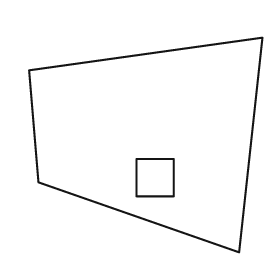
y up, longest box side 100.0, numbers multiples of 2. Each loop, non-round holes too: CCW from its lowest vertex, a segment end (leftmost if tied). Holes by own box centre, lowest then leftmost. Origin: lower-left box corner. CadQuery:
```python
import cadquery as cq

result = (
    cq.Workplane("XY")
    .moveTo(90.0, 0.0)
    .lineTo(100.0, 92.0)
    .lineTo(0.0, 78.0)
    .lineTo(4.0, 30.0)
    .close()
    .moveTo(46.0, 24.0)
    .lineTo(62.0, 24.0)
    .lineTo(62.0, 40.0)
    .lineTo(46.0, 40.0)
    .close()
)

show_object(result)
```